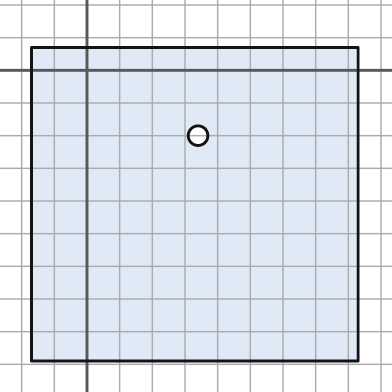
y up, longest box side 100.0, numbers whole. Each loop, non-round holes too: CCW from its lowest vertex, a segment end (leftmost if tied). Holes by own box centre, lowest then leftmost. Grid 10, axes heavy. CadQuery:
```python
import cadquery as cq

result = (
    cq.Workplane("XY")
    .moveTo(-17.0, -89.0)
    .lineTo(83.0, -89.0)
    .lineTo(83.0, 7.0)
    .lineTo(-17.0, 7.0)
    .close()
    .moveTo(34.0, -20.0)
    .circle(3.0)
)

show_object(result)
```